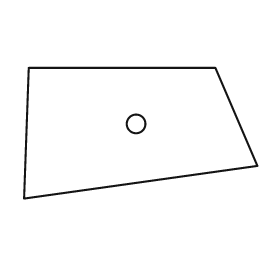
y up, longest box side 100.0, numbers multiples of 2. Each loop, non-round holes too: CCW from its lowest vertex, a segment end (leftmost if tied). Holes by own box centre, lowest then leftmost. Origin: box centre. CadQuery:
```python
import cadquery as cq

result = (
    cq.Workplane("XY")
    .moveTo(-50.0, -28.0)
    .lineTo(50.0, -14.0)
    .lineTo(32.0, 28.0)
    .lineTo(-48.0, 28.0)
    .close()
    .moveTo(-2.0, 4.0)
    .circle(4.0)
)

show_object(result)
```